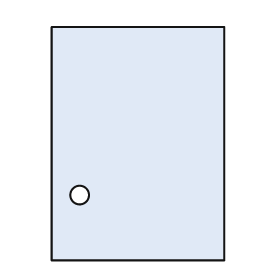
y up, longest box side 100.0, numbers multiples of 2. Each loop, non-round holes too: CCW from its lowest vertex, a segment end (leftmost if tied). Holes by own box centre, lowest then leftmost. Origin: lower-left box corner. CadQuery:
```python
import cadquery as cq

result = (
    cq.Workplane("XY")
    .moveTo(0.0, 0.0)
    .lineTo(74.0, 0.0)
    .lineTo(74.0, 100.0)
    .lineTo(0.0, 100.0)
    .close()
    .moveTo(12.0, 28.0)
    .circle(4.0)
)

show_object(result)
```